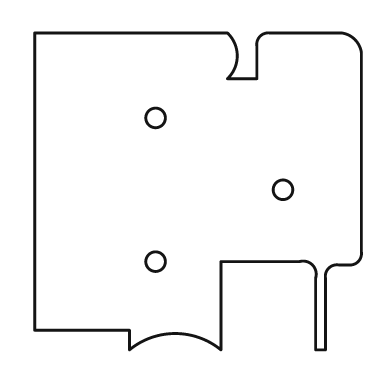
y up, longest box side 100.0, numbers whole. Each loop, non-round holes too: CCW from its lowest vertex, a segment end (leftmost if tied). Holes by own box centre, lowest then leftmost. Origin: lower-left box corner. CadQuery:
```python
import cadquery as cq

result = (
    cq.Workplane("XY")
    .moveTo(29.0, 0.0)
    .threePointArc((43.0, 5.0), (57.0, 0.0))
    .lineTo(57.0, 27.0)
    .lineTo(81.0, 27.0)
    .threePointArc((85.0, 26.0), (86.0, 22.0))
    .lineTo(86.0, 0.0)
    .lineTo(89.0, 0.0)
    .lineTo(89.0, 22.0)
    .threePointArc((90.0, 25.0), (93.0, 26.0))
    .lineTo(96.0, 26.0)
    .threePointArc((99.0, 27.0), (100.0, 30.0))
    .lineTo(100.0, 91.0)
    .threePointArc((98.0, 95.0), (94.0, 97.0))
    .lineTo(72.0, 97.0)
    .threePointArc((69.0, 96.0), (68.0, 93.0))
    .lineTo(68.0, 83.0)
    .lineTo(59.0, 83.0)
    .threePointArc((62.0, 90.0), (59.0, 97.0))
    .lineTo(0.0, 97.0)
    .lineTo(0.0, 6.0)
    .lineTo(29.0, 6.0)
    .close()
    .moveTo(37.0, 27.0)
    .circle(3.0)
    .moveTo(76.0, 49.0)
    .circle(3.0)
    .moveTo(37.0, 71.0)
    .circle(3.0)
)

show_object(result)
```